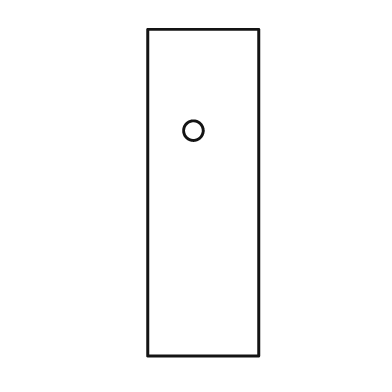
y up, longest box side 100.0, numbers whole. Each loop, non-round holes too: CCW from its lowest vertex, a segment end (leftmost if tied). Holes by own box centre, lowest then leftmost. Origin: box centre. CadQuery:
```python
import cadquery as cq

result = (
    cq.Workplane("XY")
    .moveTo(-17.0, -50.0)
    .lineTo(17.0, -50.0)
    .lineTo(17.0, 50.0)
    .lineTo(-17.0, 50.0)
    .close()
    .moveTo(-3.0, 19.0)
    .circle(3.0)
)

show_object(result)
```